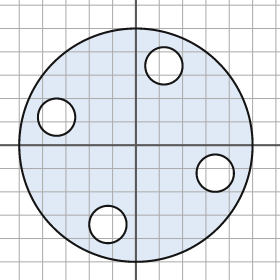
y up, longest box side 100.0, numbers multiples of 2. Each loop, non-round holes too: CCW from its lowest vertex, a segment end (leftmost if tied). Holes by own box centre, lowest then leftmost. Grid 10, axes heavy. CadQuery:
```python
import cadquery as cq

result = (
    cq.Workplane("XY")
    .moveTo(0.0, 0.0)
    .circle(50.0)
    .moveTo(-12.0, -34.0)
    .circle(8.0)
    .moveTo(34.0, -12.0)
    .circle(8.0)
    .moveTo(-34.0, 12.0)
    .circle(8.0)
    .moveTo(12.0, 34.0)
    .circle(8.0)
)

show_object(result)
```